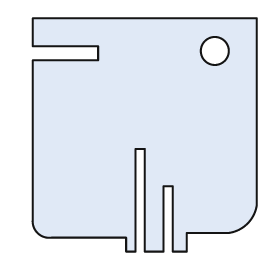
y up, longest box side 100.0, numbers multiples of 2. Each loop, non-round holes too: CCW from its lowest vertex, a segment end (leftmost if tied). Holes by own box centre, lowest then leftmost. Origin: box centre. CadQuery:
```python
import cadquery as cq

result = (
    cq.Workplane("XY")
    .moveTo(-8.0, -50.0)
    .lineTo(-4.0, -50.0)
    .lineTo(-4.0, -6.0)
    .lineTo(0.0, -6.0)
    .lineTo(0.0, -50.0)
    .lineTo(8.0, -50.0)
    .lineTo(8.0, -22.0)
    .lineTo(12.0, -22.0)
    .lineTo(12.0, -50.0)
    .lineTo(18.0, -50.0)
    .lineTo(18.0, -42.0)
    .lineTo(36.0, -42.0)
    .threePointArc((44.0, -38.0), (48.0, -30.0))
    .lineTo(48.0, 50.0)
    .lineTo(-48.0, 50.0)
    .lineTo(-48.0, 38.0)
    .lineTo(-20.0, 38.0)
    .lineTo(-20.0, 32.0)
    .lineTo(-48.0, 32.0)
    .lineTo(-48.0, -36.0)
    .threePointArc((-46.0, -42.0), (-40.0, -44.0))
    .lineTo(-8.0, -44.0)
    .close()
    .moveTo(30.0, 36.0)
    .circle(6.0)
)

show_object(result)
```